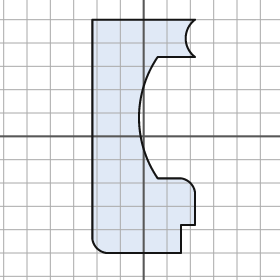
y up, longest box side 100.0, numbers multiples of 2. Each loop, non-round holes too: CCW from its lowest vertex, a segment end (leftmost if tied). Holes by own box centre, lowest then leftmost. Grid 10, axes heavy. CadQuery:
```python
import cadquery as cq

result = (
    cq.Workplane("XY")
    .moveTo(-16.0, -50.0)
    .lineTo(16.0, -50.0)
    .lineTo(16.0, -38.0)
    .lineTo(22.0, -38.0)
    .lineTo(22.0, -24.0)
    .threePointArc((20.0, -20.0), (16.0, -18.0))
    .lineTo(6.0, -18.0)
    .threePointArc((-2.0, 8.0), (6.0, 34.0))
    .lineTo(22.0, 34.0)
    .threePointArc((18.0, 42.0), (22.0, 50.0))
    .lineTo(-22.0, 50.0)
    .lineTo(-22.0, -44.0)
    .threePointArc((-20.0, -48.0), (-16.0, -50.0))
    .close()
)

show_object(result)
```